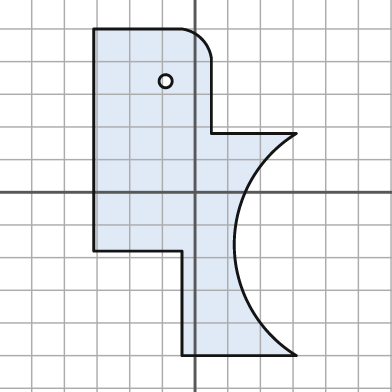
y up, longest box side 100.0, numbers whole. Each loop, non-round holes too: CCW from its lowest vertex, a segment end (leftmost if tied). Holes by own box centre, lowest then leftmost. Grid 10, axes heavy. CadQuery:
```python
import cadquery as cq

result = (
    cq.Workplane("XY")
    .moveTo(-4.0, -50.0)
    .lineTo(31.0, -50.0)
    .threePointArc((12.0, -16.0), (31.0, 18.0))
    .lineTo(5.0, 18.0)
    .lineTo(5.0, 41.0)
    .threePointArc((2.0, 47.0), (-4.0, 50.0))
    .lineTo(-31.0, 50.0)
    .lineTo(-31.0, -18.0)
    .lineTo(-4.0, -18.0)
    .close()
    .moveTo(-9.0, 34.0)
    .circle(2.0)
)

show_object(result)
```